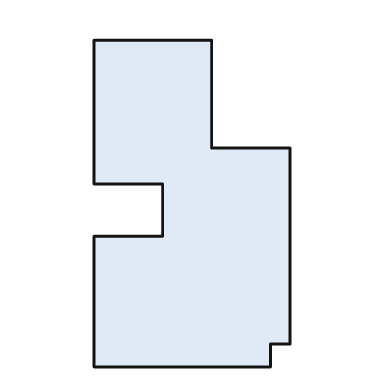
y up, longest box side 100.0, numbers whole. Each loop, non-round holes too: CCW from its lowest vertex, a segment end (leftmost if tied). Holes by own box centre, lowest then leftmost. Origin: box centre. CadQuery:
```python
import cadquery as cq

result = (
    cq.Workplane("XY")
    .moveTo(-30.0, -50.0)
    .lineTo(24.0, -50.0)
    .lineTo(24.0, -43.0)
    .lineTo(30.0, -43.0)
    .lineTo(30.0, 17.0)
    .lineTo(6.0, 17.0)
    .lineTo(6.0, 50.0)
    .lineTo(-30.0, 50.0)
    .lineTo(-30.0, 6.0)
    .lineTo(-9.0, 6.0)
    .lineTo(-9.0, -10.0)
    .lineTo(-30.0, -10.0)
    .close()
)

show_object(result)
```